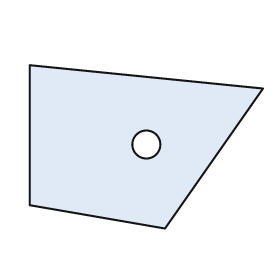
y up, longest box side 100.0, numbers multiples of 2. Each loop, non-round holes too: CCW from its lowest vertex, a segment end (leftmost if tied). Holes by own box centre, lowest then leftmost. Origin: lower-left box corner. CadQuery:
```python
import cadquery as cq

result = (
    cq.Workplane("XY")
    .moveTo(58.0, 0.0)
    .lineTo(100.0, 60.0)
    .lineTo(0.0, 70.0)
    .lineTo(0.0, 10.0)
    .close()
    .moveTo(50.0, 36.0)
    .circle(6.0)
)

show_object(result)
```